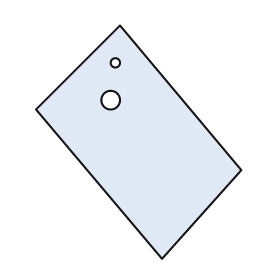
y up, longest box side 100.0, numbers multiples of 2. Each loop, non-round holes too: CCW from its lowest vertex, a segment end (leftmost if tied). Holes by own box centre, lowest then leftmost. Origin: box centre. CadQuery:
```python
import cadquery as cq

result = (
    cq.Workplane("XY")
    .moveTo(10.0, -50.0)
    .lineTo(44.0, -12.0)
    .lineTo(-8.0, 50.0)
    .lineTo(-44.0, 14.0)
    .close()
    .moveTo(-12.0, 18.0)
    .circle(4.0)
    .moveTo(-10.0, 34.0)
    .circle(2.0)
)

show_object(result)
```